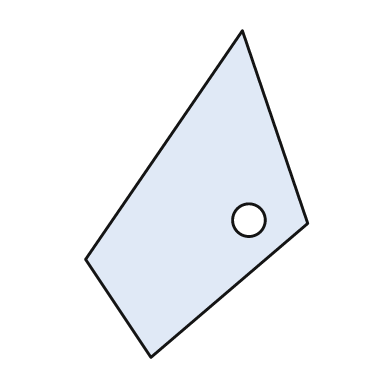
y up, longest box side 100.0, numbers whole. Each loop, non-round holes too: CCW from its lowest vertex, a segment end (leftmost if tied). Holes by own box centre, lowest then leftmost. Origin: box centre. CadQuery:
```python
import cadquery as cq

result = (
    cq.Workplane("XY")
    .moveTo(-14.0, -50.0)
    .lineTo(34.0, -9.0)
    .lineTo(14.0, 50.0)
    .lineTo(-34.0, -20.0)
    .close()
    .moveTo(16.0, -8.0)
    .circle(5.0)
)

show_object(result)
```